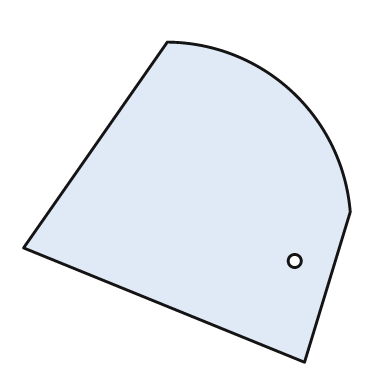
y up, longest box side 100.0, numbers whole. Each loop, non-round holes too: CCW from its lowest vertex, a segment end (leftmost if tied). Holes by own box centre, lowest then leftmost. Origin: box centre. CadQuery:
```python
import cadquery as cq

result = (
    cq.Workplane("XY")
    .moveTo(36.0, -49.0)
    .lineTo(50.0, -3.0)
    .threePointArc((32.0, 34.0), (-6.0, 49.0))
    .lineTo(-50.0, -14.0)
    .close()
    .moveTo(33.0, -18.0)
    .circle(2.0)
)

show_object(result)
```